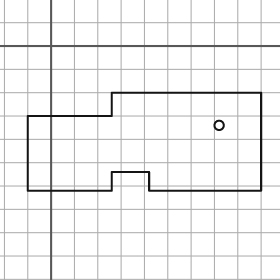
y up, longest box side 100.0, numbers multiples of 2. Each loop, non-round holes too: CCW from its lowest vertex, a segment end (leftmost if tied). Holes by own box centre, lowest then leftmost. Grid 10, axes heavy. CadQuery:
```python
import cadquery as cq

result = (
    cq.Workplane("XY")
    .moveTo(-10.0, -62.0)
    .lineTo(26.0, -62.0)
    .lineTo(26.0, -54.0)
    .lineTo(42.0, -54.0)
    .lineTo(42.0, -62.0)
    .lineTo(90.0, -62.0)
    .lineTo(90.0, -20.0)
    .lineTo(26.0, -20.0)
    .lineTo(26.0, -30.0)
    .lineTo(-10.0, -30.0)
    .close()
    .moveTo(72.0, -34.0)
    .circle(2.0)
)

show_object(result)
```